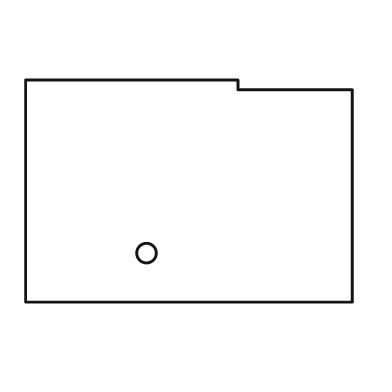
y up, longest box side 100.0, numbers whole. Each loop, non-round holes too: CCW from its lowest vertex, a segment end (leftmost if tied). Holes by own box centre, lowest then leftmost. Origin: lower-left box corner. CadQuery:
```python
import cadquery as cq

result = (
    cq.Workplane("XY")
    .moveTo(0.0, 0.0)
    .lineTo(100.0, 0.0)
    .lineTo(100.0, 65.0)
    .lineTo(65.0, 65.0)
    .lineTo(65.0, 68.0)
    .lineTo(0.0, 68.0)
    .close()
    .moveTo(37.0, 15.0)
    .circle(3.0)
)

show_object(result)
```